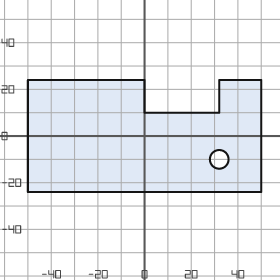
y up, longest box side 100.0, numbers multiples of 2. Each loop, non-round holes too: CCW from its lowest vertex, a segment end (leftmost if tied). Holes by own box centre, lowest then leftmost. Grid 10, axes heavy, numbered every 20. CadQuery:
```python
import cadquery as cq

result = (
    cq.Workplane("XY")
    .moveTo(-50.0, -24.0)
    .lineTo(50.0, -24.0)
    .lineTo(50.0, 24.0)
    .lineTo(32.0, 24.0)
    .lineTo(32.0, 10.0)
    .lineTo(0.0, 10.0)
    .lineTo(0.0, 24.0)
    .lineTo(-50.0, 24.0)
    .close()
    .moveTo(32.0, -10.0)
    .circle(4.0)
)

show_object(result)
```